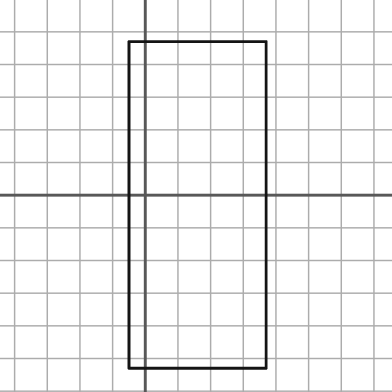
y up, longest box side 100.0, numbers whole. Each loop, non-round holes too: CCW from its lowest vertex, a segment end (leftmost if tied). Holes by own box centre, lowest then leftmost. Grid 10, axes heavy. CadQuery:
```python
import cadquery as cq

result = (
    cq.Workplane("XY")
    .moveTo(-5.0, -53.0)
    .lineTo(37.0, -53.0)
    .lineTo(37.0, 47.0)
    .lineTo(-5.0, 47.0)
    .close()
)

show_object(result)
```